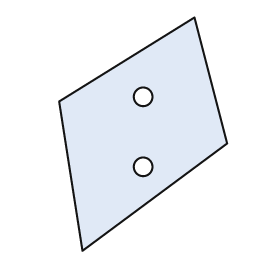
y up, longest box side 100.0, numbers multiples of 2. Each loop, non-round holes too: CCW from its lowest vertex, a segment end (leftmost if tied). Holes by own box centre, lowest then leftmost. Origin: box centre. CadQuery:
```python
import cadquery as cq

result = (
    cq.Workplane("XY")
    .moveTo(-26.0, -50.0)
    .lineTo(36.0, -4.0)
    .lineTo(22.0, 50.0)
    .lineTo(-36.0, 14.0)
    .close()
    .moveTo(0.0, -14.0)
    .circle(4.0)
    .moveTo(0.0, 16.0)
    .circle(4.0)
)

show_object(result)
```